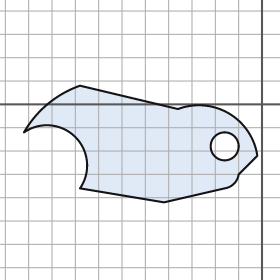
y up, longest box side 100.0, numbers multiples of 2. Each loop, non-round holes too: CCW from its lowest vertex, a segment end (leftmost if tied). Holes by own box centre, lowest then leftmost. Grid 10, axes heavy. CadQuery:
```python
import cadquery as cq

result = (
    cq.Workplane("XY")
    .moveTo(-42.0, -42.0)
    .lineTo(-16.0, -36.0)
    .threePointArc((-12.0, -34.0), (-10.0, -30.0))
    .lineTo(-2.0, -22.0)
    .threePointArc((-14.0, -4.0), (-36.0, -2.0))
    .lineTo(-78.0, 8.0)
    .threePointArc((-92.0, 0.0), (-102.0, -12.0))
    .threePointArc((-80.0, -14.0), (-78.0, -36.0))
    .close()
    .moveTo(-16.0, -18.0)
    .circle(6.0)
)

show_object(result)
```